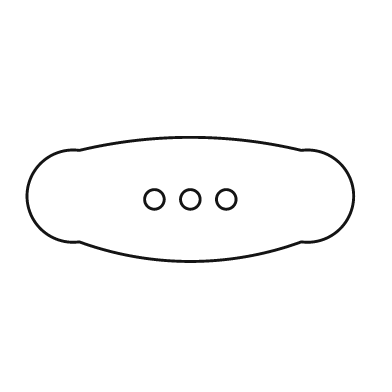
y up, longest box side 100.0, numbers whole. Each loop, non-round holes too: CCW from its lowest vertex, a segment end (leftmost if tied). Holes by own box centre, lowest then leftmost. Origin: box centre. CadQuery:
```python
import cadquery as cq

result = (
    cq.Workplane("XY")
    .moveTo(-34.0, -13.0)
    .threePointArc((0.0, -19.0), (34.0, -13.0))
    .threePointArc((50.0, 1.0), (34.0, 15.0))
    .threePointArc((0.0, 19.0), (-34.0, 15.0))
    .threePointArc((-50.0, 1.0), (-34.0, -13.0))
    .close()
    .moveTo(-11.0, 0.0)
    .circle(3.0)
    .moveTo(0.0, 0.0)
    .circle(3.0)
    .moveTo(11.0, 0.0)
    .circle(3.0)
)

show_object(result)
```